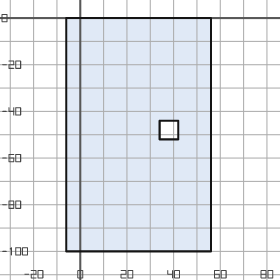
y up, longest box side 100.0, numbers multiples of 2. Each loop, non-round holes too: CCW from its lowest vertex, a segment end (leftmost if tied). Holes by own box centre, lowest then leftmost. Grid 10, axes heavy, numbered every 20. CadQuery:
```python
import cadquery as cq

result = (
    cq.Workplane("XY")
    .moveTo(-6.0, -100.0)
    .lineTo(56.0, -100.0)
    .lineTo(56.0, 0.0)
    .lineTo(-6.0, 0.0)
    .close()
    .moveTo(34.0, -52.0)
    .lineTo(42.0, -52.0)
    .lineTo(42.0, -44.0)
    .lineTo(34.0, -44.0)
    .close()
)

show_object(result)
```